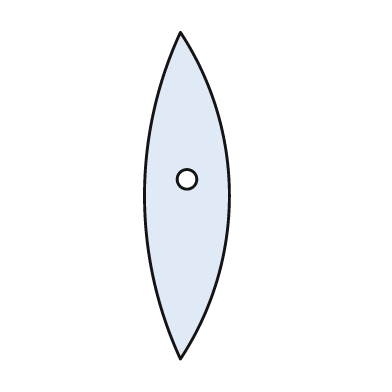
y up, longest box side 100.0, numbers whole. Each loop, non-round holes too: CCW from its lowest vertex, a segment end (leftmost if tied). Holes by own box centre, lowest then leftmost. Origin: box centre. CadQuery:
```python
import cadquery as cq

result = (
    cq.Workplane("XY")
    .moveTo(-2.0, -50.0)
    .threePointArc((13.0, 0.0), (-2.0, 50.0))
    .threePointArc((-13.0, 0.0), (-2.0, -50.0))
    .close()
    .moveTo(0.0, 5.0)
    .circle(3.0)
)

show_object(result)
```